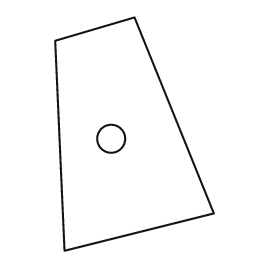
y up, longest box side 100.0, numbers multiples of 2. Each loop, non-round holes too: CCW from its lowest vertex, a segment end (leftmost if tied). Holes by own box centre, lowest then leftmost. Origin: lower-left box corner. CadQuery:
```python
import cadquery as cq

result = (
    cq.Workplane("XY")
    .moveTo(4.0, 0.0)
    .lineTo(68.0, 16.0)
    .lineTo(34.0, 100.0)
    .lineTo(0.0, 90.0)
    .close()
    .moveTo(24.0, 48.0)
    .circle(6.0)
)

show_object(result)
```